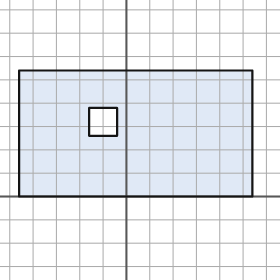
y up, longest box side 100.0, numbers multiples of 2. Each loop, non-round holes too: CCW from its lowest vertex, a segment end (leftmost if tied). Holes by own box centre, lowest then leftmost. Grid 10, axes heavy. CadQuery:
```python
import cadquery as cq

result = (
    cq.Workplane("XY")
    .moveTo(-46.0, 0.0)
    .lineTo(54.0, 0.0)
    .lineTo(54.0, 54.0)
    .lineTo(-46.0, 54.0)
    .close()
    .moveTo(-16.0, 26.0)
    .lineTo(-4.0, 26.0)
    .lineTo(-4.0, 38.0)
    .lineTo(-16.0, 38.0)
    .close()
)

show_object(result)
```